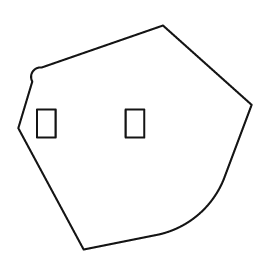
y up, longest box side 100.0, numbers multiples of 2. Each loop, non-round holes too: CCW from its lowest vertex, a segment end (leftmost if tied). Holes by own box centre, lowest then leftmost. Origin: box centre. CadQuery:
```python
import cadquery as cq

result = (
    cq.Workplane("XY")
    .moveTo(-22.0, -48.0)
    .lineTo(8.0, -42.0)
    .threePointArc((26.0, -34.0), (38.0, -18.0))
    .lineTo(50.0, 14.0)
    .lineTo(12.0, 48.0)
    .lineTo(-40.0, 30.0)
    .threePointArc((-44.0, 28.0), (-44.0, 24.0))
    .lineTo(-50.0, 4.0)
    .close()
    .moveTo(-42.0, 0.0)
    .lineTo(-34.0, 0.0)
    .lineTo(-34.0, 12.0)
    .lineTo(-42.0, 12.0)
    .close()
    .moveTo(-4.0, 0.0)
    .lineTo(4.0, 0.0)
    .lineTo(4.0, 12.0)
    .lineTo(-4.0, 12.0)
    .close()
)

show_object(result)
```